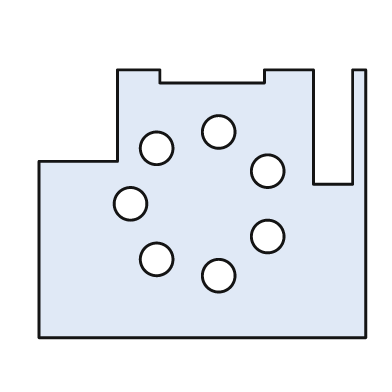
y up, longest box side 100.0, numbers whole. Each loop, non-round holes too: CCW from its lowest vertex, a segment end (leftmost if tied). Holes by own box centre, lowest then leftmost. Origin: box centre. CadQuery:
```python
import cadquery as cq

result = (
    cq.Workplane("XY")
    .moveTo(-50.0, -41.0)
    .lineTo(50.0, -41.0)
    .lineTo(50.0, 41.0)
    .lineTo(46.0, 41.0)
    .lineTo(46.0, 6.0)
    .lineTo(34.0, 6.0)
    .lineTo(34.0, 41.0)
    .lineTo(19.0, 41.0)
    .lineTo(19.0, 37.0)
    .lineTo(-13.0, 37.0)
    .lineTo(-13.0, 41.0)
    .lineTo(-26.0, 41.0)
    .lineTo(-26.0, 13.0)
    .lineTo(-50.0, 13.0)
    .close()
    .moveTo(5.0, -22.0)
    .circle(5.0)
    .moveTo(-14.0, -17.0)
    .circle(5.0)
    .moveTo(20.0, -10.0)
    .circle(5.0)
    .moveTo(-22.0, 0.0)
    .circle(5.0)
    .moveTo(20.0, 10.0)
    .circle(5.0)
    .moveTo(-14.0, 17.0)
    .circle(5.0)
    .moveTo(5.0, 22.0)
    .circle(5.0)
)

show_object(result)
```